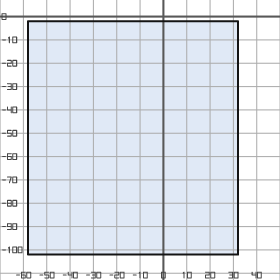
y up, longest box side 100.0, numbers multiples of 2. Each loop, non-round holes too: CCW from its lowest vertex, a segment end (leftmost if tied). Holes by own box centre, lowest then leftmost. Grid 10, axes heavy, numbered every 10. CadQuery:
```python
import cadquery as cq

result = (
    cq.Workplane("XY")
    .moveTo(-58.0, -102.0)
    .lineTo(32.0, -102.0)
    .lineTo(32.0, -2.0)
    .lineTo(-58.0, -2.0)
    .close()
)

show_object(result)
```